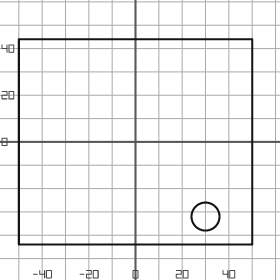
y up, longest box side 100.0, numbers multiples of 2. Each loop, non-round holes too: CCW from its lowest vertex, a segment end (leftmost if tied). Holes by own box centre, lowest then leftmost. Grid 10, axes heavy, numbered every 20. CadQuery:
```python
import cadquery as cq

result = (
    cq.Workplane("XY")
    .moveTo(-50.0, -44.0)
    .lineTo(50.0, -44.0)
    .lineTo(50.0, 44.0)
    .lineTo(-50.0, 44.0)
    .close()
    .moveTo(30.0, -32.0)
    .circle(6.0)
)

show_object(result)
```